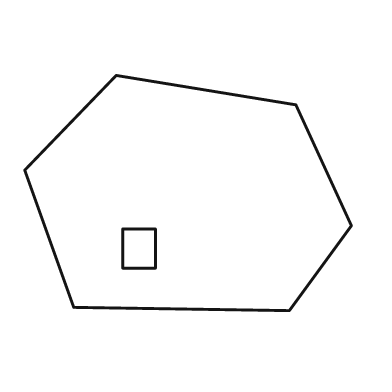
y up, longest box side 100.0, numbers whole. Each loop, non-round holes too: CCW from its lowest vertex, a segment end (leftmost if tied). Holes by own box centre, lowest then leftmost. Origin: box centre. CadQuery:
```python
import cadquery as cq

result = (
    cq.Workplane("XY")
    .moveTo(31.0, -36.0)
    .lineTo(50.0, -10.0)
    .lineTo(33.0, 27.0)
    .lineTo(-22.0, 36.0)
    .lineTo(-50.0, 7.0)
    .lineTo(-35.0, -35.0)
    .close()
    .moveTo(-20.0, -23.0)
    .lineTo(-10.0, -23.0)
    .lineTo(-10.0, -11.0)
    .lineTo(-20.0, -11.0)
    .close()
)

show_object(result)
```